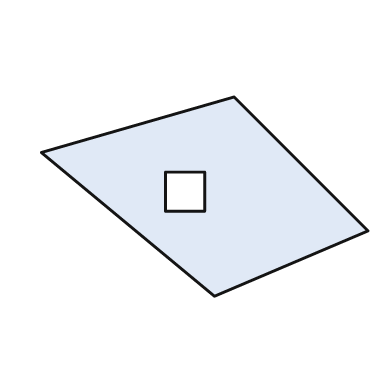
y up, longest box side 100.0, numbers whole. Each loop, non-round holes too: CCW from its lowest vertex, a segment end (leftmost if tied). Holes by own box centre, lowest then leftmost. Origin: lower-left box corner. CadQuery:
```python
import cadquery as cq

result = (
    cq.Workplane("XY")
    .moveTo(53.0, 0.0)
    .lineTo(100.0, 20.0)
    .lineTo(59.0, 61.0)
    .lineTo(0.0, 44.0)
    .close()
    .moveTo(38.0, 26.0)
    .lineTo(50.0, 26.0)
    .lineTo(50.0, 38.0)
    .lineTo(38.0, 38.0)
    .close()
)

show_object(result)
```